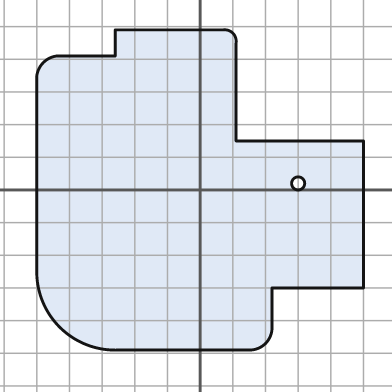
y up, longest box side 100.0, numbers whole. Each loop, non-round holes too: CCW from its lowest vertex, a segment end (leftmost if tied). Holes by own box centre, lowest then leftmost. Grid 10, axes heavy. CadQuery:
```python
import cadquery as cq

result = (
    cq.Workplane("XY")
    .moveTo(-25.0, -49.0)
    .lineTo(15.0, -49.0)
    .threePointArc((20.0, -47.0), (22.0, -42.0))
    .lineTo(22.0, -30.0)
    .lineTo(50.0, -30.0)
    .lineTo(50.0, 15.0)
    .lineTo(11.0, 15.0)
    .lineTo(11.0, 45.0)
    .threePointArc((10.0, 48.0), (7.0, 49.0))
    .lineTo(-26.0, 49.0)
    .lineTo(-26.0, 41.0)
    .lineTo(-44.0, 41.0)
    .threePointArc((-48.0, 39.0), (-50.0, 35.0))
    .lineTo(-50.0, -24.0)
    .threePointArc((-43.0, -42.0), (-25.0, -49.0))
    .close()
    .moveTo(30.0, 2.0)
    .circle(2.0)
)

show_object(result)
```